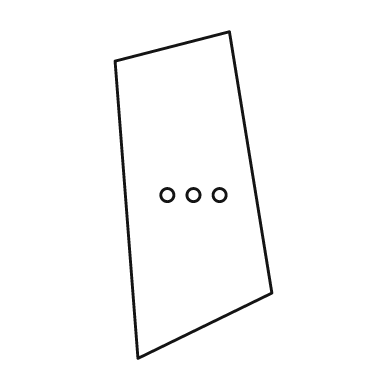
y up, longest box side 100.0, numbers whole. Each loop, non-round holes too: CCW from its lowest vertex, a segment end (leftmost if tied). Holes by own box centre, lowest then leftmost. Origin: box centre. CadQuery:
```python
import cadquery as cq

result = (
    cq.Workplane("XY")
    .moveTo(-17.0, -50.0)
    .lineTo(24.0, -30.0)
    .lineTo(11.0, 50.0)
    .lineTo(-24.0, 41.0)
    .close()
    .moveTo(-8.0, 0.0)
    .circle(2.0)
    .moveTo(0.0, 0.0)
    .circle(2.0)
    .moveTo(8.0, 0.0)
    .circle(2.0)
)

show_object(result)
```